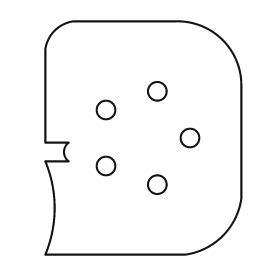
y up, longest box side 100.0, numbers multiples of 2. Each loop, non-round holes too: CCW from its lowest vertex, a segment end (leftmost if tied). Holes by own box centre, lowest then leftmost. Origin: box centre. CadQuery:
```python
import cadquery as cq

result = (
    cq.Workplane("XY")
    .moveTo(-42.0, -50.0)
    .lineTo(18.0, -50.0)
    .threePointArc((34.0, -42.0), (42.0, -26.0))
    .lineTo(42.0, 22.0)
    .threePointArc((34.0, 42.0), (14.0, 50.0))
    .lineTo(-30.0, 50.0)
    .threePointArc((-38.0, 46.0), (-42.0, 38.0))
    .lineTo(-42.0, -2.0)
    .lineTo(-32.0, -2.0)
    .threePointArc((-34.0, -6.0), (-32.0, -10.0))
    .lineTo(-42.0, -10.0)
    .threePointArc((-38.0, -30.0), (-42.0, -50.0))
    .close()
    .moveTo(6.0, -20.0)
    .circle(4.0)
    .moveTo(-16.0, -12.0)
    .circle(4.0)
    .moveTo(20.0, 0.0)
    .circle(4.0)
    .moveTo(-16.0, 12.0)
    .circle(4.0)
    .moveTo(6.0, 20.0)
    .circle(4.0)
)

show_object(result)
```